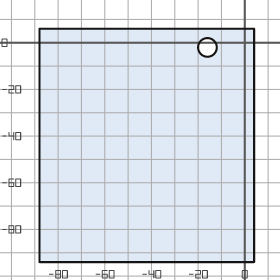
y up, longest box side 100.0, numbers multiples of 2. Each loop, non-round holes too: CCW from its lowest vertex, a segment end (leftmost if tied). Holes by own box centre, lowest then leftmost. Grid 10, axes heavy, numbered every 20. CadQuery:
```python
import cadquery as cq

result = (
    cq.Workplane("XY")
    .moveTo(-88.0, -94.0)
    .lineTo(4.0, -94.0)
    .lineTo(4.0, 6.0)
    .lineTo(-88.0, 6.0)
    .close()
    .moveTo(-16.0, -2.0)
    .circle(4.0)
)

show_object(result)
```